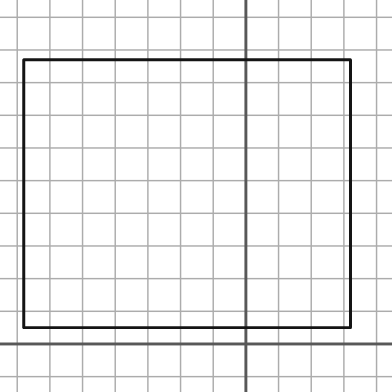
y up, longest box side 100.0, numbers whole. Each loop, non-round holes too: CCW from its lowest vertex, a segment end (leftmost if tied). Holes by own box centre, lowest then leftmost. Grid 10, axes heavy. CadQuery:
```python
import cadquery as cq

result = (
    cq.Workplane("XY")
    .moveTo(-68.0, 5.0)
    .lineTo(32.0, 5.0)
    .lineTo(32.0, 87.0)
    .lineTo(-68.0, 87.0)
    .close()
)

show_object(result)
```